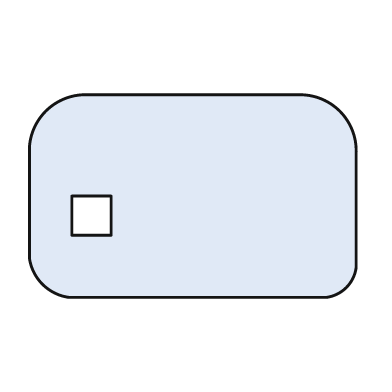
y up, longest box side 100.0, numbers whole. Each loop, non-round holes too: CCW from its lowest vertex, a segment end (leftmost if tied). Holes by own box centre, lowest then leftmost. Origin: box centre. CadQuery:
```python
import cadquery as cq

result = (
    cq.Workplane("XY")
    .moveTo(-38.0, -31.0)
    .lineTo(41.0, -31.0)
    .threePointArc((47.0, -28.0), (50.0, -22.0))
    .lineTo(50.0, 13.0)
    .threePointArc((45.0, 26.0), (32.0, 31.0))
    .lineTo(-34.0, 31.0)
    .threePointArc((-45.0, 26.0), (-50.0, 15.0))
    .lineTo(-50.0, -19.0)
    .threePointArc((-46.0, -27.0), (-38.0, -31.0))
    .close()
    .moveTo(-37.0, -12.0)
    .lineTo(-25.0, -12.0)
    .lineTo(-25.0, 0.0)
    .lineTo(-37.0, 0.0)
    .close()
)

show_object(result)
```